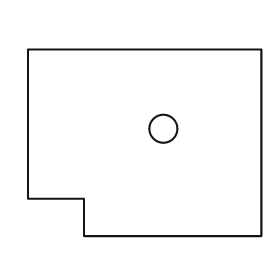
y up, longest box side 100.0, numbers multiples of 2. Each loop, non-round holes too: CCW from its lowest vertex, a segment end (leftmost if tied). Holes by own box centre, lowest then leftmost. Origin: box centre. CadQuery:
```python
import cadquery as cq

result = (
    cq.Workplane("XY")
    .moveTo(-26.0, -40.0)
    .lineTo(50.0, -40.0)
    .lineTo(50.0, 40.0)
    .lineTo(-50.0, 40.0)
    .lineTo(-50.0, -24.0)
    .lineTo(-26.0, -24.0)
    .close()
    .moveTo(8.0, 6.0)
    .circle(6.0)
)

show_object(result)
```